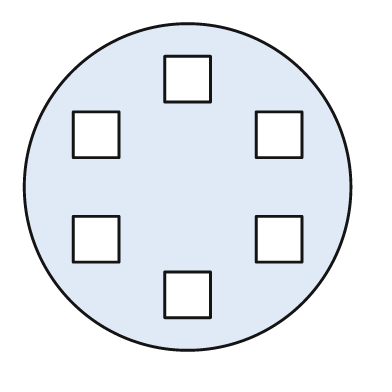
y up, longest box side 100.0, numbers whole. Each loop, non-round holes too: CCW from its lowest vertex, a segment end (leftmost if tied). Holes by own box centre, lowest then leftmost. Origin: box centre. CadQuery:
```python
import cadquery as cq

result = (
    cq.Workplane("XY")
    .moveTo(0.0, 0.0)
    .circle(50.0)
    .moveTo(-7.0, -40.0)
    .lineTo(7.0, -40.0)
    .lineTo(7.0, -26.0)
    .lineTo(-7.0, -26.0)
    .close()
    .moveTo(-35.0, -23.0)
    .lineTo(-21.0, -23.0)
    .lineTo(-21.0, -9.0)
    .lineTo(-35.0, -9.0)
    .close()
    .moveTo(21.0, -23.0)
    .lineTo(35.0, -23.0)
    .lineTo(35.0, -9.0)
    .lineTo(21.0, -9.0)
    .close()
    .moveTo(-35.0, 9.0)
    .lineTo(-21.0, 9.0)
    .lineTo(-21.0, 23.0)
    .lineTo(-35.0, 23.0)
    .close()
    .moveTo(21.0, 9.0)
    .lineTo(35.0, 9.0)
    .lineTo(35.0, 23.0)
    .lineTo(21.0, 23.0)
    .close()
    .moveTo(-7.0, 26.0)
    .lineTo(7.0, 26.0)
    .lineTo(7.0, 40.0)
    .lineTo(-7.0, 40.0)
    .close()
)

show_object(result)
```